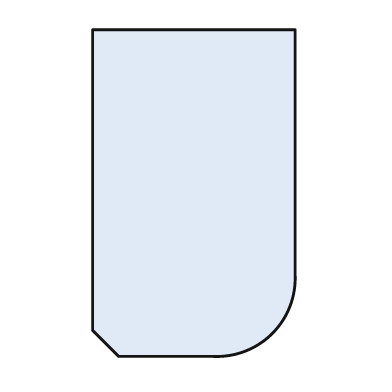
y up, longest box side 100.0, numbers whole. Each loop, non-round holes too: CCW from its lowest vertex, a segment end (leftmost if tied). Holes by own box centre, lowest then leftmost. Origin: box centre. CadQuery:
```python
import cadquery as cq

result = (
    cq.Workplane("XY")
    .moveTo(-23.0, -50.0)
    .lineTo(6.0, -50.0)
    .threePointArc((24.0, -43.0), (31.0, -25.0))
    .lineTo(31.0, 50.0)
    .lineTo(-31.0, 50.0)
    .lineTo(-31.0, -42.0)
    .close()
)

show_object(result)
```